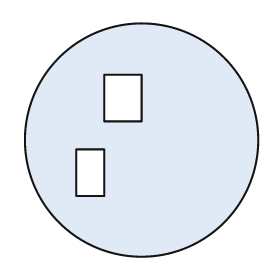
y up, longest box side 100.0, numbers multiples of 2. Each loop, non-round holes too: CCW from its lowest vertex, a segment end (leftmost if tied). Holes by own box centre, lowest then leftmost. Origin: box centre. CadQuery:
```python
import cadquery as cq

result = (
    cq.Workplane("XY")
    .moveTo(0.0, 0.0)
    .circle(50.0)
    .moveTo(-28.0, -24.0)
    .lineTo(-16.0, -24.0)
    .lineTo(-16.0, -4.0)
    .lineTo(-28.0, -4.0)
    .close()
    .moveTo(-16.0, 8.0)
    .lineTo(0.0, 8.0)
    .lineTo(0.0, 28.0)
    .lineTo(-16.0, 28.0)
    .close()
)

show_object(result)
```